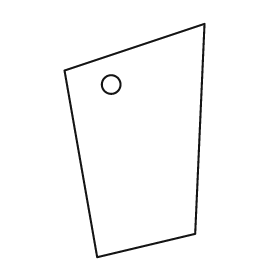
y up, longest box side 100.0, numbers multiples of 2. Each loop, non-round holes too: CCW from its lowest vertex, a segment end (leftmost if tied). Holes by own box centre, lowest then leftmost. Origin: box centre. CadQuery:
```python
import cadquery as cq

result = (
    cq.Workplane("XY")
    .moveTo(-16.0, -50.0)
    .lineTo(26.0, -40.0)
    .lineTo(30.0, 50.0)
    .lineTo(-30.0, 30.0)
    .close()
    .moveTo(-10.0, 24.0)
    .circle(4.0)
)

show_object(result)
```